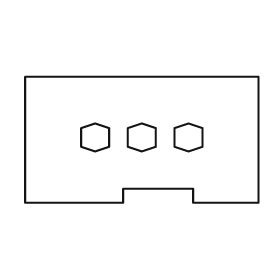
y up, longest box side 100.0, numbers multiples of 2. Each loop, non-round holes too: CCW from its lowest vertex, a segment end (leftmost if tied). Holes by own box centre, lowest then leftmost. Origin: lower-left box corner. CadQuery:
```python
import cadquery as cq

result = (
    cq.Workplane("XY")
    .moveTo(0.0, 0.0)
    .lineTo(42.0, 0.0)
    .lineTo(42.0, 6.0)
    .lineTo(72.0, 6.0)
    .lineTo(72.0, 0.0)
    .lineTo(100.0, 0.0)
    .lineTo(100.0, 54.0)
    .lineTo(0.0, 54.0)
    .close()
    .moveTo(30.0, 22.0)
    .lineTo(36.0, 24.0)
    .lineTo(36.0, 32.0)
    .lineTo(30.0, 34.0)
    .lineTo(24.0, 32.0)
    .lineTo(24.0, 24.0)
    .close()
    .moveTo(50.0, 22.0)
    .lineTo(56.0, 24.0)
    .lineTo(56.0, 32.0)
    .lineTo(50.0, 34.0)
    .lineTo(44.0, 32.0)
    .lineTo(44.0, 24.0)
    .close()
    .moveTo(70.0, 22.0)
    .lineTo(76.0, 24.0)
    .lineTo(76.0, 32.0)
    .lineTo(70.0, 34.0)
    .lineTo(64.0, 32.0)
    .lineTo(64.0, 24.0)
    .close()
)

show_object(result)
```